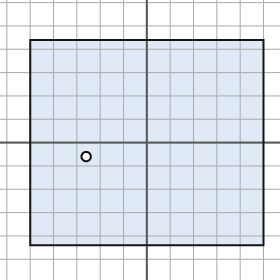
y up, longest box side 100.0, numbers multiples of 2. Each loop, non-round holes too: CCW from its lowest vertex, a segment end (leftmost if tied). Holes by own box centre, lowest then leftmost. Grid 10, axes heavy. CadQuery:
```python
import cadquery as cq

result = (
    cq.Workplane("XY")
    .moveTo(-50.0, -44.0)
    .lineTo(50.0, -44.0)
    .lineTo(50.0, 44.0)
    .lineTo(-50.0, 44.0)
    .close()
    .moveTo(-26.0, -6.0)
    .circle(2.0)
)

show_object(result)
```